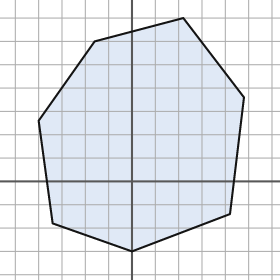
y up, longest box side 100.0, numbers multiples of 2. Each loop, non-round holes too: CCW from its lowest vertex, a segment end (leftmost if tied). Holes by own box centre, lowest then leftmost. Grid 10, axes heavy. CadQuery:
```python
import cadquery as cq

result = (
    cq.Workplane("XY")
    .moveTo(0.0, -30.0)
    .lineTo(42.0, -14.0)
    .lineTo(48.0, 36.0)
    .lineTo(22.0, 70.0)
    .lineTo(-16.0, 60.0)
    .lineTo(-40.0, 26.0)
    .lineTo(-34.0, -18.0)
    .close()
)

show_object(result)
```